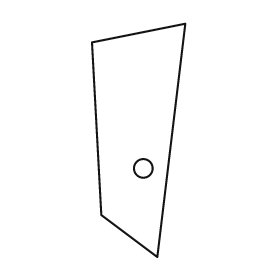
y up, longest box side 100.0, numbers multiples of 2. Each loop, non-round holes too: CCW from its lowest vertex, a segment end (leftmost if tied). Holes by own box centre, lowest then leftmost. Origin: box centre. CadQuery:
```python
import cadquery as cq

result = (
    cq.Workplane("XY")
    .moveTo(8.0, -50.0)
    .lineTo(20.0, 50.0)
    .lineTo(-20.0, 42.0)
    .lineTo(-16.0, -32.0)
    .close()
    .moveTo(2.0, -12.0)
    .circle(4.0)
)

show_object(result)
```